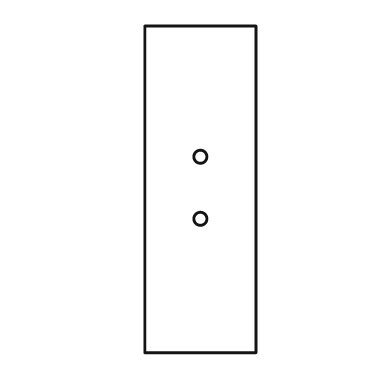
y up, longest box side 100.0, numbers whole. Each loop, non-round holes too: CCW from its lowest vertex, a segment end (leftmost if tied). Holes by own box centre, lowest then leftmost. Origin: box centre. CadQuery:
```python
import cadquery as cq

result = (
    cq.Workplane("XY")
    .moveTo(-17.0, -50.0)
    .lineTo(17.0, -50.0)
    .lineTo(17.0, 50.0)
    .lineTo(-17.0, 50.0)
    .close()
    .moveTo(0.0, -9.0)
    .circle(2.0)
    .moveTo(0.0, 10.0)
    .circle(2.0)
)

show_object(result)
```